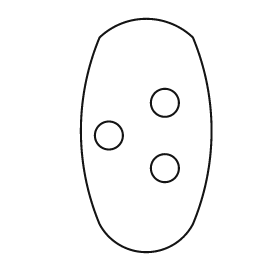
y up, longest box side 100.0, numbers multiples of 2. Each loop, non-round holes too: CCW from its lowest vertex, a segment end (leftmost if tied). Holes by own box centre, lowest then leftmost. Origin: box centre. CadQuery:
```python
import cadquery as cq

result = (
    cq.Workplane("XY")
    .moveTo(-20.0, -38.0)
    .threePointArc((0.0, -50.0), (20.0, -38.0))
    .threePointArc((28.0, 2.0), (20.0, 42.0))
    .threePointArc((0.0, 50.0), (-20.0, 42.0))
    .threePointArc((-28.0, 2.0), (-20.0, -38.0))
    .close()
    .moveTo(8.0, -14.0)
    .circle(6.0)
    .moveTo(-16.0, 0.0)
    .circle(6.0)
    .moveTo(8.0, 14.0)
    .circle(6.0)
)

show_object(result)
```